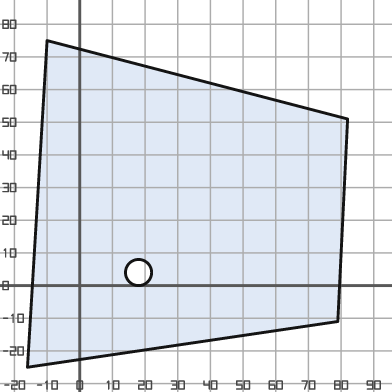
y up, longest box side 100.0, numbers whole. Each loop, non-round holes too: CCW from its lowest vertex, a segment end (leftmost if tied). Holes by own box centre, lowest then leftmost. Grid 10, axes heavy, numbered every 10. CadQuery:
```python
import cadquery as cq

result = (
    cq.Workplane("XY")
    .moveTo(-16.0, -25.0)
    .lineTo(79.0, -11.0)
    .lineTo(82.0, 51.0)
    .lineTo(-10.0, 75.0)
    .close()
    .moveTo(18.0, 4.0)
    .circle(4.0)
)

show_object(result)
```